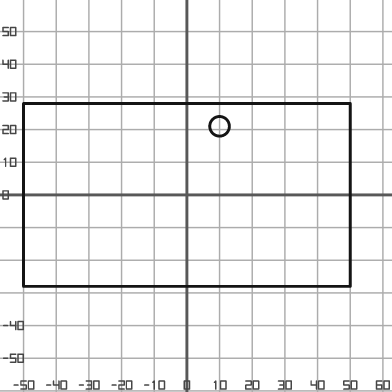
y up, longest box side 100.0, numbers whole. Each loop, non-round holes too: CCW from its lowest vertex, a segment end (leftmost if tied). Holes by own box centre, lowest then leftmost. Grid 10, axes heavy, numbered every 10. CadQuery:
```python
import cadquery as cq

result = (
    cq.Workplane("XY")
    .moveTo(-50.0, -28.0)
    .lineTo(50.0, -28.0)
    .lineTo(50.0, 28.0)
    .lineTo(-50.0, 28.0)
    .close()
    .moveTo(10.0, 21.0)
    .circle(3.0)
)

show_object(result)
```